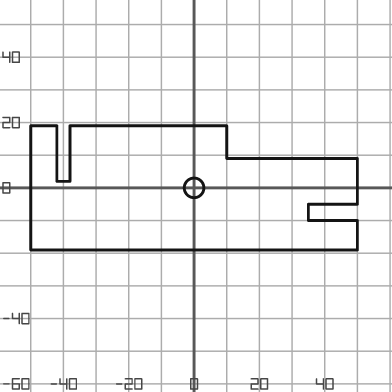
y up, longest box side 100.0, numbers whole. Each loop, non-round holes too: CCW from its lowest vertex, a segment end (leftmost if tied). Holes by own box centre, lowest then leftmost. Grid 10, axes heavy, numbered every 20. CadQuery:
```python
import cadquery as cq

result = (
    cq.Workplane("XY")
    .moveTo(-50.0, -19.0)
    .lineTo(50.0, -19.0)
    .lineTo(50.0, -10.0)
    .lineTo(35.0, -10.0)
    .lineTo(35.0, -5.0)
    .lineTo(50.0, -5.0)
    .lineTo(50.0, 9.0)
    .lineTo(10.0, 9.0)
    .lineTo(10.0, 19.0)
    .lineTo(-38.0, 19.0)
    .lineTo(-38.0, 2.0)
    .lineTo(-42.0, 2.0)
    .lineTo(-42.0, 19.0)
    .lineTo(-50.0, 19.0)
    .close()
    .moveTo(0.0, 0.0)
    .circle(3.0)
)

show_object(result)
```